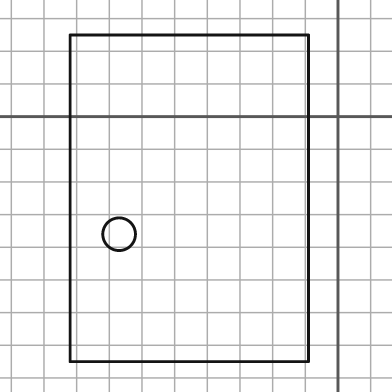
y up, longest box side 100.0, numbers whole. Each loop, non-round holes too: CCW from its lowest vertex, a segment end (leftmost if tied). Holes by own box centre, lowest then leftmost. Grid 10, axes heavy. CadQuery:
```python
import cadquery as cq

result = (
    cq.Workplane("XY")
    .moveTo(-82.0, -75.0)
    .lineTo(-9.0, -75.0)
    .lineTo(-9.0, 25.0)
    .lineTo(-82.0, 25.0)
    .close()
    .moveTo(-67.0, -36.0)
    .circle(5.0)
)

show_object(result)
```